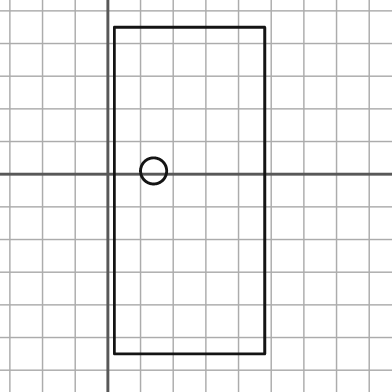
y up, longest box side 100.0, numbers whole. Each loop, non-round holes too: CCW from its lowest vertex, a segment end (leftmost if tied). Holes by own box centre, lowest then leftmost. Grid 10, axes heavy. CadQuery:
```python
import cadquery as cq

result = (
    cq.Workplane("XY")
    .moveTo(2.0, -55.0)
    .lineTo(48.0, -55.0)
    .lineTo(48.0, 45.0)
    .lineTo(2.0, 45.0)
    .close()
    .moveTo(14.0, 1.0)
    .circle(4.0)
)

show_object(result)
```